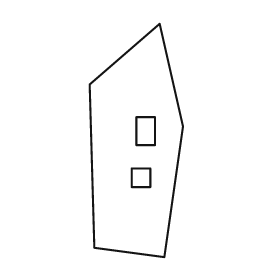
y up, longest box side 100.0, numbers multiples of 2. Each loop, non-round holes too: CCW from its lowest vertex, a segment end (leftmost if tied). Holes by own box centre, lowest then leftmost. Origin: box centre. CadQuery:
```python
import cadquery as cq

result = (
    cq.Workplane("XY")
    .moveTo(12.0, -50.0)
    .lineTo(20.0, 6.0)
    .lineTo(10.0, 50.0)
    .lineTo(-20.0, 24.0)
    .lineTo(-18.0, -46.0)
    .close()
    .moveTo(-2.0, -20.0)
    .lineTo(6.0, -20.0)
    .lineTo(6.0, -12.0)
    .lineTo(-2.0, -12.0)
    .close()
    .moveTo(0.0, -2.0)
    .lineTo(8.0, -2.0)
    .lineTo(8.0, 10.0)
    .lineTo(0.0, 10.0)
    .close()
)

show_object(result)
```